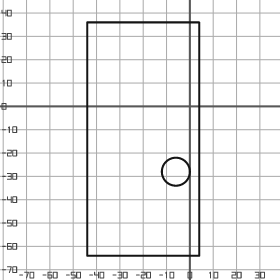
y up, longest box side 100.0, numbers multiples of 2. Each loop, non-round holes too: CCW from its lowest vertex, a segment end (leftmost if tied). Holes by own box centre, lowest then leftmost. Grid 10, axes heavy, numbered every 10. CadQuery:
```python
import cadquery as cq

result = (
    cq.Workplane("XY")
    .moveTo(-44.0, -64.0)
    .lineTo(4.0, -64.0)
    .lineTo(4.0, 36.0)
    .lineTo(-44.0, 36.0)
    .close()
    .moveTo(-6.0, -28.0)
    .circle(6.0)
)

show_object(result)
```